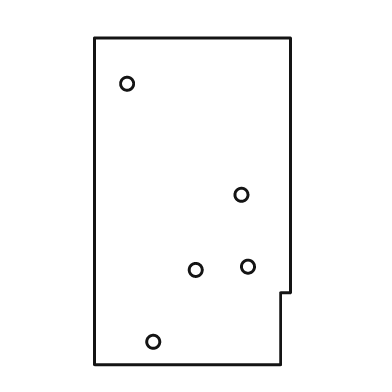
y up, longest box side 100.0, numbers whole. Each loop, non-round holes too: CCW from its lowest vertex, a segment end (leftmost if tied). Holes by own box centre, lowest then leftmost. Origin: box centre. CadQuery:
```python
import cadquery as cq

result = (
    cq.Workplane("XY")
    .moveTo(-30.0, -50.0)
    .lineTo(27.0, -50.0)
    .lineTo(27.0, -28.0)
    .lineTo(30.0, -28.0)
    .lineTo(30.0, 50.0)
    .lineTo(-30.0, 50.0)
    .close()
    .moveTo(-12.0, -43.0)
    .circle(2.0)
    .moveTo(1.0, -21.0)
    .circle(2.0)
    .moveTo(17.0, -20.0)
    .circle(2.0)
    .moveTo(15.0, 2.0)
    .circle(2.0)
    .moveTo(-20.0, 36.0)
    .circle(2.0)
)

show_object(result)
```